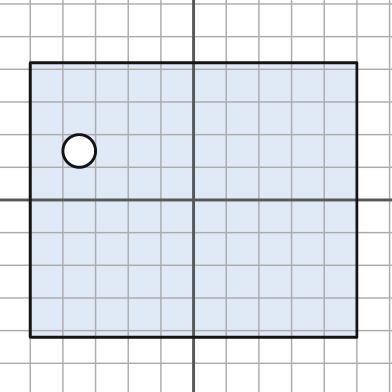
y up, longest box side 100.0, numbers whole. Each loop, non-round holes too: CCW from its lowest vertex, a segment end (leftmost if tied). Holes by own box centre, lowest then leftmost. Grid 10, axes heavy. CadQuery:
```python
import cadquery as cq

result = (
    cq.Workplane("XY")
    .moveTo(-50.0, -42.0)
    .lineTo(50.0, -42.0)
    .lineTo(50.0, 42.0)
    .lineTo(-50.0, 42.0)
    .close()
    .moveTo(-35.0, 15.0)
    .circle(5.0)
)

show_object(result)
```